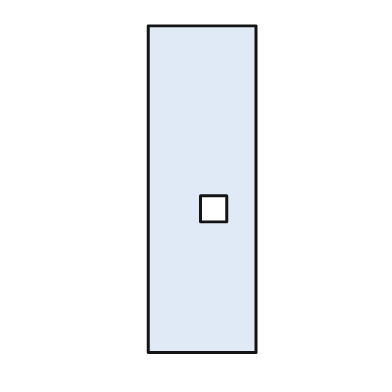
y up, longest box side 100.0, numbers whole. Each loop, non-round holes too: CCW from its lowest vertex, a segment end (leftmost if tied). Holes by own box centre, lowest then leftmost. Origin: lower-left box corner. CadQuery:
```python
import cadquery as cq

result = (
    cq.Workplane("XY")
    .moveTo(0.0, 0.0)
    .lineTo(33.0, 0.0)
    .lineTo(33.0, 100.0)
    .lineTo(0.0, 100.0)
    .close()
    .moveTo(16.0, 40.0)
    .lineTo(24.0, 40.0)
    .lineTo(24.0, 48.0)
    .lineTo(16.0, 48.0)
    .close()
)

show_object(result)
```